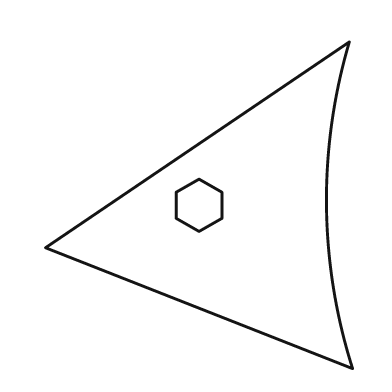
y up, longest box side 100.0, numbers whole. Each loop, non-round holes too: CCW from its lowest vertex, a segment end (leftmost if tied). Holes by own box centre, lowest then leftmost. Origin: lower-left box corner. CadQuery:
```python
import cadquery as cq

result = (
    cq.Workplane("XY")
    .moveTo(94.0, 0.0)
    .threePointArc((86.0, 50.0), (93.0, 100.0))
    .lineTo(0.0, 37.0)
    .close()
    .moveTo(47.0, 42.0)
    .lineTo(54.0, 46.0)
    .lineTo(54.0, 54.0)
    .lineTo(47.0, 58.0)
    .lineTo(40.0, 54.0)
    .lineTo(40.0, 46.0)
    .close()
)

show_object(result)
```